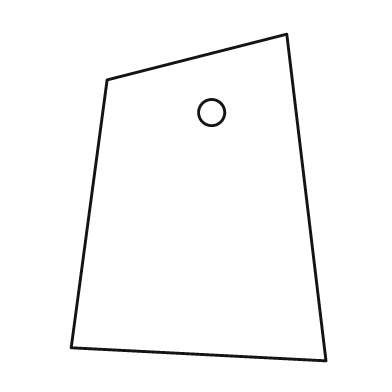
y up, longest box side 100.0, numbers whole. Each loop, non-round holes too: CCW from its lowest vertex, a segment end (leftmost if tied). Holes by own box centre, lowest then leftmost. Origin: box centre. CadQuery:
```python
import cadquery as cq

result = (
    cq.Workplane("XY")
    .moveTo(39.0, -50.0)
    .lineTo(27.0, 50.0)
    .lineTo(-28.0, 36.0)
    .lineTo(-39.0, -46.0)
    .close()
    .moveTo(4.0, 26.0)
    .circle(4.0)
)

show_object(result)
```